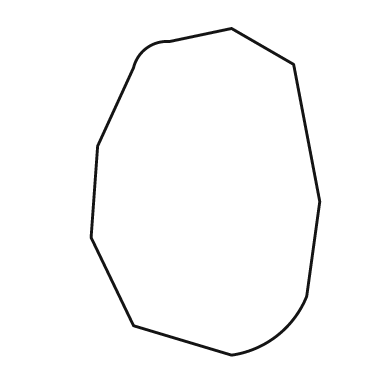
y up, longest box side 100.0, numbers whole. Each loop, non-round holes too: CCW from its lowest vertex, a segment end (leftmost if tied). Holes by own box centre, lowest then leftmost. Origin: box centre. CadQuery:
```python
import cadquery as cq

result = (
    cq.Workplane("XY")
    .moveTo(8.0, -50.0)
    .threePointArc((22.0, -44.0), (31.0, -32.0))
    .lineTo(35.0, -3.0)
    .lineTo(27.0, 39.0)
    .lineTo(8.0, 50.0)
    .lineTo(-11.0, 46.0)
    .threePointArc((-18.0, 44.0), (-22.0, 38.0))
    .lineTo(-33.0, 14.0)
    .lineTo(-35.0, -14.0)
    .lineTo(-22.0, -41.0)
    .close()
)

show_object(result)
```